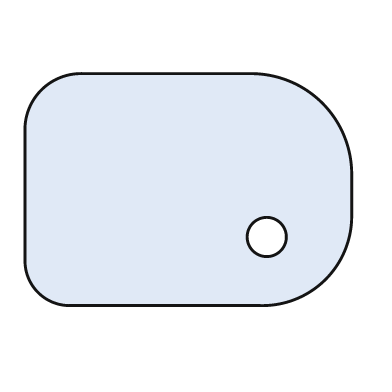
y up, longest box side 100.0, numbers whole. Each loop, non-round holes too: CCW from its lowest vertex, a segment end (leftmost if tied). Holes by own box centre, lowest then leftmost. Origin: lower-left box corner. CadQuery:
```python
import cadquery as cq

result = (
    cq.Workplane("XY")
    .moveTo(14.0, 0.0)
    .lineTo(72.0, 0.0)
    .threePointArc((92.0, 8.0), (100.0, 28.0))
    .lineTo(100.0, 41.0)
    .threePointArc((91.0, 62.0), (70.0, 71.0))
    .lineTo(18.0, 71.0)
    .threePointArc((5.0, 66.0), (0.0, 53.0))
    .lineTo(0.0, 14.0)
    .threePointArc((4.0, 4.0), (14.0, 0.0))
    .close()
    .moveTo(74.0, 21.0)
    .circle(6.0)
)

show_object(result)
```